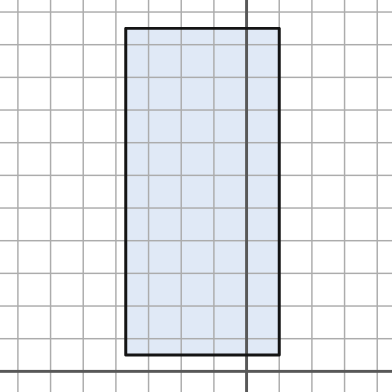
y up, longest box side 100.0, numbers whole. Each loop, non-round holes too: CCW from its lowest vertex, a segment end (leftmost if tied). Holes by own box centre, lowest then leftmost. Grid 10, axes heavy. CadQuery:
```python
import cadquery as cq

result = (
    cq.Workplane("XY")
    .moveTo(-37.0, 5.0)
    .lineTo(10.0, 5.0)
    .lineTo(10.0, 105.0)
    .lineTo(-37.0, 105.0)
    .close()
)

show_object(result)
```